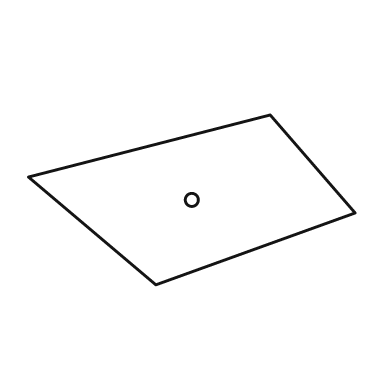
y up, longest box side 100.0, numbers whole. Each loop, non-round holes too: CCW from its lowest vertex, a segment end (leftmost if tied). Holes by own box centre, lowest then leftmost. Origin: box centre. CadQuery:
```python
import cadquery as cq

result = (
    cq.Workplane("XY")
    .moveTo(-11.0, -26.0)
    .lineTo(50.0, -4.0)
    .lineTo(24.0, 26.0)
    .lineTo(-50.0, 7.0)
    .close()
    .moveTo(0.0, 0.0)
    .circle(2.0)
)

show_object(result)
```